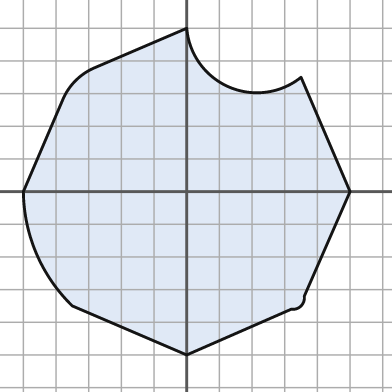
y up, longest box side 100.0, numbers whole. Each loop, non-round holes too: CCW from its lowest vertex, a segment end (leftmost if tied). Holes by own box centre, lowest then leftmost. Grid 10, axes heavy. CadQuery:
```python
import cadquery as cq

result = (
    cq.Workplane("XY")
    .moveTo(0.0, -50.0)
    .lineTo(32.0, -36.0)
    .threePointArc((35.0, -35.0), (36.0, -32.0))
    .lineTo(50.0, 0.0)
    .lineTo(35.0, 35.0)
    .threePointArc((13.0, 32.0), (0.0, 50.0))
    .lineTo(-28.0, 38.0)
    .threePointArc((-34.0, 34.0), (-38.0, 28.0))
    .lineTo(-50.0, 0.0)
    .threePointArc((-46.0, -19.0), (-35.0, -35.0))
    .close()
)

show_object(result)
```